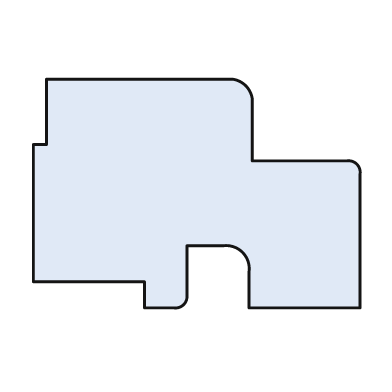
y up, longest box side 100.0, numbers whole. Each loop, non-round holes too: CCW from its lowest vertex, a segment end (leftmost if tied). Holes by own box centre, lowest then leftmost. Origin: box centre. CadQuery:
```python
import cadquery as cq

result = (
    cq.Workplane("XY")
    .moveTo(-16.0, -35.0)
    .lineTo(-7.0, -35.0)
    .threePointArc((-4.0, -34.0), (-3.0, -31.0))
    .lineTo(-3.0, -16.0)
    .lineTo(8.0, -16.0)
    .threePointArc((14.0, -18.0), (16.0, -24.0))
    .lineTo(16.0, -35.0)
    .lineTo(50.0, -35.0)
    .lineTo(50.0, 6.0)
    .threePointArc((49.0, 9.0), (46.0, 10.0))
    .lineTo(17.0, 10.0)
    .lineTo(17.0, 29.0)
    .threePointArc((15.0, 33.0), (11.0, 35.0))
    .lineTo(-46.0, 35.0)
    .lineTo(-46.0, 15.0)
    .lineTo(-50.0, 15.0)
    .lineTo(-50.0, -27.0)
    .lineTo(-16.0, -27.0)
    .close()
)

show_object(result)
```